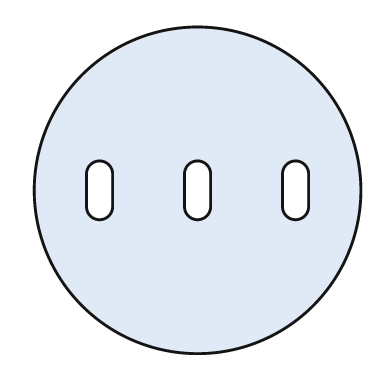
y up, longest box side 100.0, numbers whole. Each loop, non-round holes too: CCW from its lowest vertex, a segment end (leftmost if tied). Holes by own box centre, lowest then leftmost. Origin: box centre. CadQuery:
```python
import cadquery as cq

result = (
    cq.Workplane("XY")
    .moveTo(0.0, 0.0)
    .circle(50.0)
    .moveTo(-34.0, -5.0)
    .threePointArc((-30.0, -9.0), (-26.0, -5.0))
    .lineTo(-26.0, 5.0)
    .threePointArc((-30.0, 9.0), (-34.0, 5.0))
    .close()
    .moveTo(-4.0, -5.0)
    .threePointArc((0.0, -9.0), (4.0, -5.0))
    .lineTo(4.0, 5.0)
    .threePointArc((0.0, 9.0), (-4.0, 5.0))
    .close()
    .moveTo(26.0, -5.0)
    .threePointArc((30.0, -9.0), (34.0, -5.0))
    .lineTo(34.0, 5.0)
    .threePointArc((30.0, 9.0), (26.0, 5.0))
    .close()
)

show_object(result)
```